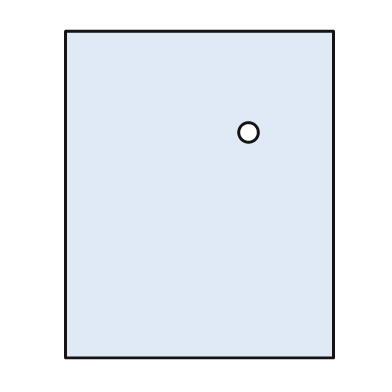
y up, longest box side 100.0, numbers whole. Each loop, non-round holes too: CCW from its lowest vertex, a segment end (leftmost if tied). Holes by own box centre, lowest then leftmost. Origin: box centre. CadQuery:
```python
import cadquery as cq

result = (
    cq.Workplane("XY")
    .moveTo(-41.0, -50.0)
    .lineTo(41.0, -50.0)
    .lineTo(41.0, 50.0)
    .lineTo(-41.0, 50.0)
    .close()
    .moveTo(15.0, 19.0)
    .circle(3.0)
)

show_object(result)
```